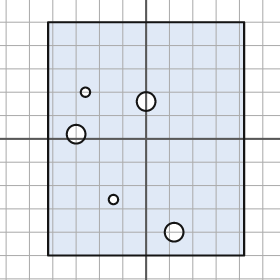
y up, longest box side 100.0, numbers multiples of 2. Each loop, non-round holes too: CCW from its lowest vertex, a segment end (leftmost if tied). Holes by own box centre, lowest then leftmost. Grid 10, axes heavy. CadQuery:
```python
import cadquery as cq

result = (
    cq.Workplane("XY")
    .moveTo(-42.0, -50.0)
    .lineTo(42.0, -50.0)
    .lineTo(42.0, 50.0)
    .lineTo(-42.0, 50.0)
    .close()
    .moveTo(12.0, -40.0)
    .circle(4.0)
    .moveTo(-14.0, -26.0)
    .circle(2.0)
    .moveTo(-30.0, 2.0)
    .circle(4.0)
    .moveTo(0.0, 16.0)
    .circle(4.0)
    .moveTo(-26.0, 20.0)
    .circle(2.0)
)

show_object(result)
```